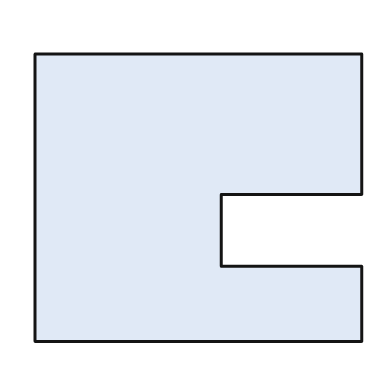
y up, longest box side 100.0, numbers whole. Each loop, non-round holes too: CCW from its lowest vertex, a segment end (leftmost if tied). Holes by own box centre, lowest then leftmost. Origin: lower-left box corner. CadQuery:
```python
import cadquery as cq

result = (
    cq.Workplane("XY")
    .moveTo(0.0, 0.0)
    .lineTo(100.0, 0.0)
    .lineTo(100.0, 23.0)
    .lineTo(57.0, 23.0)
    .lineTo(57.0, 45.0)
    .lineTo(100.0, 45.0)
    .lineTo(100.0, 88.0)
    .lineTo(0.0, 88.0)
    .close()
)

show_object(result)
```